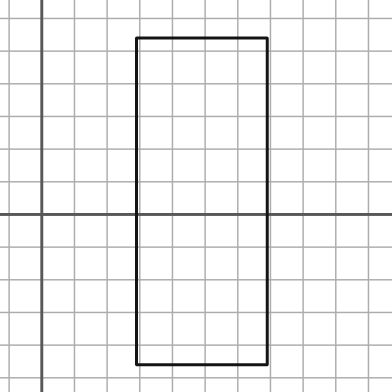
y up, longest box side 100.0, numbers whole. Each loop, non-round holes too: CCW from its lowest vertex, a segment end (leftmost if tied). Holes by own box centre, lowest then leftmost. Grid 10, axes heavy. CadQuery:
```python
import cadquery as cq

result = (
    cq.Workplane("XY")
    .moveTo(29.0, -46.0)
    .lineTo(69.0, -46.0)
    .lineTo(69.0, 54.0)
    .lineTo(29.0, 54.0)
    .close()
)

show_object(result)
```